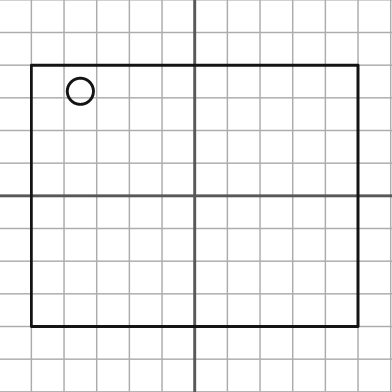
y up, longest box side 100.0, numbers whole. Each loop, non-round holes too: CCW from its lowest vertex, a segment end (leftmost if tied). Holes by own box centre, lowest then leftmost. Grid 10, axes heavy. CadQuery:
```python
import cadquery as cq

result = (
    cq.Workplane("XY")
    .moveTo(-50.0, -40.0)
    .lineTo(50.0, -40.0)
    .lineTo(50.0, 40.0)
    .lineTo(-50.0, 40.0)
    .close()
    .moveTo(-35.0, 32.0)
    .circle(4.0)
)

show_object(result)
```